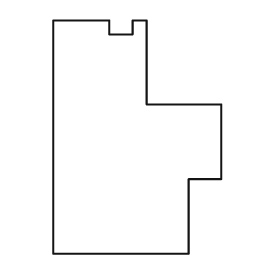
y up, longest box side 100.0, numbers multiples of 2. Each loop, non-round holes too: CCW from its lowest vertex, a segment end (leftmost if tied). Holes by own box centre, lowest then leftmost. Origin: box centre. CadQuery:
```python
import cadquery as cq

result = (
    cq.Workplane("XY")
    .moveTo(-36.0, -50.0)
    .lineTo(22.0, -50.0)
    .lineTo(22.0, -18.0)
    .lineTo(36.0, -18.0)
    .lineTo(36.0, 14.0)
    .lineTo(4.0, 14.0)
    .lineTo(4.0, 50.0)
    .lineTo(-2.0, 50.0)
    .lineTo(-2.0, 44.0)
    .lineTo(-12.0, 44.0)
    .lineTo(-12.0, 50.0)
    .lineTo(-36.0, 50.0)
    .close()
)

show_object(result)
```